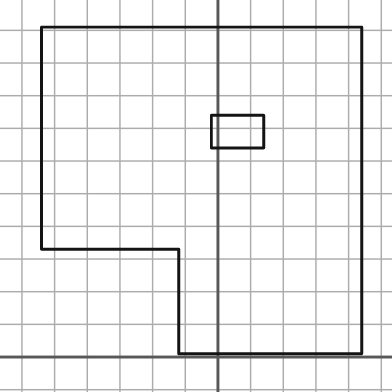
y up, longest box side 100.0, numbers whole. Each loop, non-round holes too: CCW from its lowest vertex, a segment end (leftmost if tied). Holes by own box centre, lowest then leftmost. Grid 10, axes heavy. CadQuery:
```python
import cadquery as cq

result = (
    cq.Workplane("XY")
    .moveTo(-12.0, 1.0)
    .lineTo(44.0, 1.0)
    .lineTo(44.0, 101.0)
    .lineTo(-54.0, 101.0)
    .lineTo(-54.0, 33.0)
    .lineTo(-12.0, 33.0)
    .close()
    .moveTo(-2.0, 64.0)
    .lineTo(14.0, 64.0)
    .lineTo(14.0, 74.0)
    .lineTo(-2.0, 74.0)
    .close()
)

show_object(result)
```